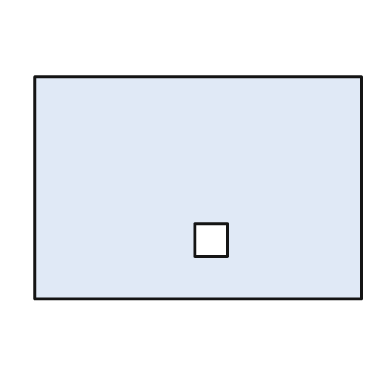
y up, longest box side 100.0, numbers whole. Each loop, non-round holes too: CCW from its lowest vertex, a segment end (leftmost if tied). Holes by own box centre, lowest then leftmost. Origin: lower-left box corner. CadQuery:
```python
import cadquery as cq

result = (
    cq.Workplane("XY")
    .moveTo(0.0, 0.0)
    .lineTo(100.0, 0.0)
    .lineTo(100.0, 68.0)
    .lineTo(0.0, 68.0)
    .close()
    .moveTo(49.0, 13.0)
    .lineTo(59.0, 13.0)
    .lineTo(59.0, 23.0)
    .lineTo(49.0, 23.0)
    .close()
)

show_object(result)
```